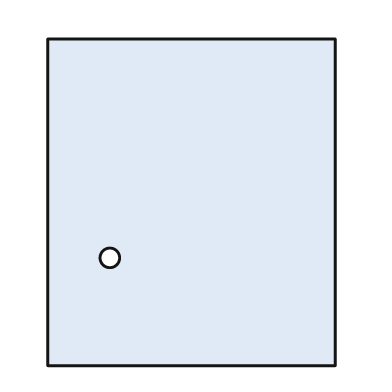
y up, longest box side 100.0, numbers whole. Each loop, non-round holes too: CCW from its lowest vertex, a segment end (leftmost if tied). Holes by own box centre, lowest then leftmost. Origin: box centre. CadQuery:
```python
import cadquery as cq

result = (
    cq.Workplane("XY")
    .moveTo(-44.0, -50.0)
    .lineTo(44.0, -50.0)
    .lineTo(44.0, 50.0)
    .lineTo(-44.0, 50.0)
    .close()
    .moveTo(-25.0, -17.0)
    .circle(3.0)
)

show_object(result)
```